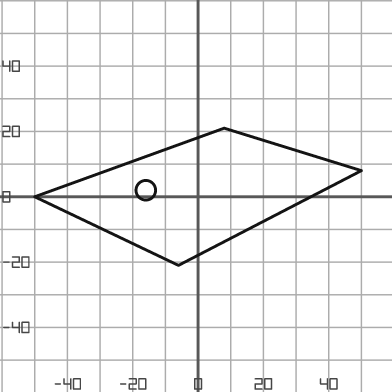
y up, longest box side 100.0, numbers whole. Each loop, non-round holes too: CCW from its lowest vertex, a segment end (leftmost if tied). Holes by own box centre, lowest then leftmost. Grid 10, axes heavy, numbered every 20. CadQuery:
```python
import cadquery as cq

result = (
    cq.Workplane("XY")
    .moveTo(-6.0, -21.0)
    .lineTo(50.0, 8.0)
    .lineTo(8.0, 21.0)
    .lineTo(-50.0, 0.0)
    .close()
    .moveTo(-16.0, 2.0)
    .circle(3.0)
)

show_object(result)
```